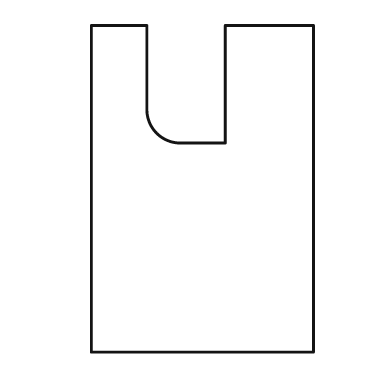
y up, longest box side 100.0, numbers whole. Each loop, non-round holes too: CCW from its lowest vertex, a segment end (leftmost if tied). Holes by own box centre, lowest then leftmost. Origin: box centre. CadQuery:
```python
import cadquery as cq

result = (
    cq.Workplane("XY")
    .moveTo(-34.0, -50.0)
    .lineTo(34.0, -50.0)
    .lineTo(34.0, 50.0)
    .lineTo(7.0, 50.0)
    .lineTo(7.0, 14.0)
    .lineTo(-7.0, 14.0)
    .threePointArc((-14.0, 17.0), (-17.0, 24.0))
    .lineTo(-17.0, 50.0)
    .lineTo(-34.0, 50.0)
    .close()
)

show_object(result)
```